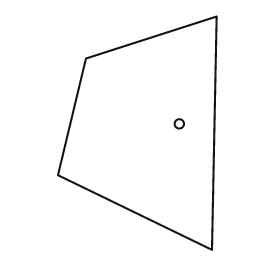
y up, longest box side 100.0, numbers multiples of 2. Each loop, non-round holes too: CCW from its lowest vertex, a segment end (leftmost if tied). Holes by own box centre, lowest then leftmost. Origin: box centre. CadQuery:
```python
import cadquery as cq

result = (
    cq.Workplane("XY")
    .moveTo(32.0, -50.0)
    .lineTo(34.0, 50.0)
    .lineTo(-22.0, 32.0)
    .lineTo(-34.0, -18.0)
    .close()
    .moveTo(18.0, 4.0)
    .circle(2.0)
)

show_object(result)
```